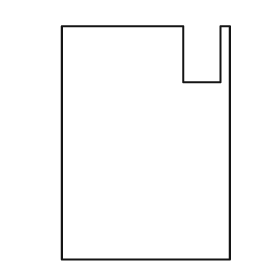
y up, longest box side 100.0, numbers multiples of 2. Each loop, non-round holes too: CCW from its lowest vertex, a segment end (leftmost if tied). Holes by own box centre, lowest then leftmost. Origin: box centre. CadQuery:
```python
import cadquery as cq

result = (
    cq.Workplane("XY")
    .moveTo(-36.0, -50.0)
    .lineTo(36.0, -50.0)
    .lineTo(36.0, 50.0)
    .lineTo(32.0, 50.0)
    .lineTo(32.0, 26.0)
    .lineTo(16.0, 26.0)
    .lineTo(16.0, 50.0)
    .lineTo(-36.0, 50.0)
    .close()
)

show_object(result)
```